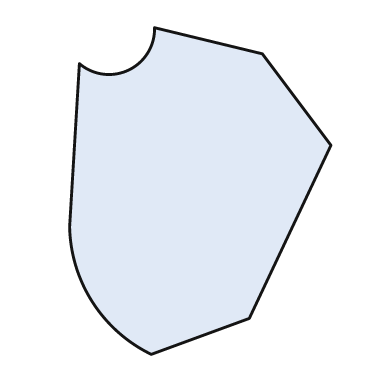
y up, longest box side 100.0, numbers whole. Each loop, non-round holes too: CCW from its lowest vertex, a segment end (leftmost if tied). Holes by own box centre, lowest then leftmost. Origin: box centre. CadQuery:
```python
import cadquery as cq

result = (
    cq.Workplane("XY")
    .moveTo(-15.0, -50.0)
    .lineTo(15.0, -39.0)
    .lineTo(40.0, 14.0)
    .lineTo(19.0, 42.0)
    .lineTo(-14.0, 50.0)
    .threePointArc((-22.0, 37.0), (-37.0, 39.0))
    .lineTo(-40.0, -11.0)
    .threePointArc((-33.0, -34.0), (-15.0, -50.0))
    .close()
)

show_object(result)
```